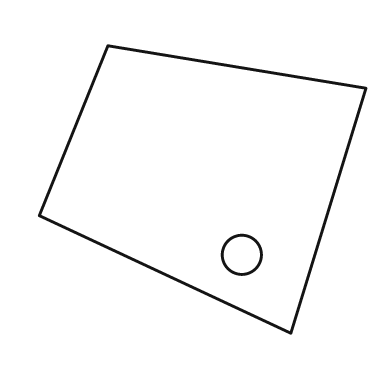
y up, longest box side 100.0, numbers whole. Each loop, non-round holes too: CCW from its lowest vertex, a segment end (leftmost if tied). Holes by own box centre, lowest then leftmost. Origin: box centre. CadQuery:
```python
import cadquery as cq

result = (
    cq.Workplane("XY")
    .moveTo(27.0, -44.0)
    .lineTo(50.0, 31.0)
    .lineTo(-29.0, 44.0)
    .lineTo(-50.0, -8.0)
    .close()
    .moveTo(12.0, -20.0)
    .circle(6.0)
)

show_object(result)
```